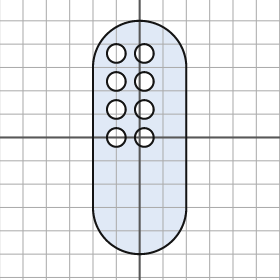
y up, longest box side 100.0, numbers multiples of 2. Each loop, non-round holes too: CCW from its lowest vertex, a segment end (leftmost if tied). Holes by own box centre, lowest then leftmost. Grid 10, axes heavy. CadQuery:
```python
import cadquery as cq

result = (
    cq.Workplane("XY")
    .moveTo(-20.0, -30.0)
    .threePointArc((0.0, -50.0), (20.0, -30.0))
    .lineTo(20.0, 30.0)
    .threePointArc((0.0, 50.0), (-20.0, 30.0))
    .close()
    .moveTo(-10.0, 0.0)
    .circle(4.0)
    .moveTo(2.0, 0.0)
    .circle(4.0)
    .moveTo(-10.0, 12.0)
    .circle(4.0)
    .moveTo(2.0, 12.0)
    .circle(4.0)
    .moveTo(-10.0, 24.0)
    .circle(4.0)
    .moveTo(2.0, 24.0)
    .circle(4.0)
    .moveTo(-10.0, 36.0)
    .circle(4.0)
    .moveTo(2.0, 36.0)
    .circle(4.0)
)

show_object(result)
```